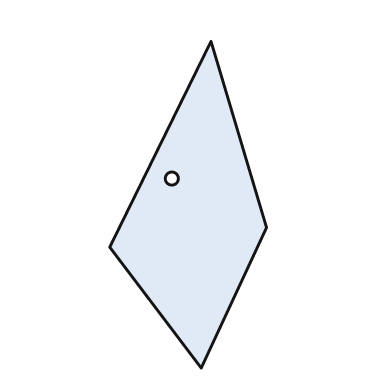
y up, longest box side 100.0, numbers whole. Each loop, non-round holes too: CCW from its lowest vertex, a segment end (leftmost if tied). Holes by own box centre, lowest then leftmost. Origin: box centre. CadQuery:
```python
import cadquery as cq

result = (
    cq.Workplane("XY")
    .moveTo(4.0, -50.0)
    .lineTo(24.0, -7.0)
    .lineTo(7.0, 50.0)
    .lineTo(-24.0, -13.0)
    .close()
    .moveTo(-5.0, 8.0)
    .circle(2.0)
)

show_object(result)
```